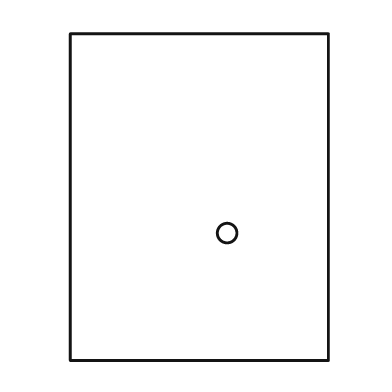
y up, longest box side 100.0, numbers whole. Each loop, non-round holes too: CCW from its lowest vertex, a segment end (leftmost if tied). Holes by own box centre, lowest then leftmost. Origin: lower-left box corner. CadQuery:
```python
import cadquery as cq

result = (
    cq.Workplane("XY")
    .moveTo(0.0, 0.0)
    .lineTo(79.0, 0.0)
    .lineTo(79.0, 100.0)
    .lineTo(0.0, 100.0)
    .close()
    .moveTo(48.0, 39.0)
    .circle(3.0)
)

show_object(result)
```